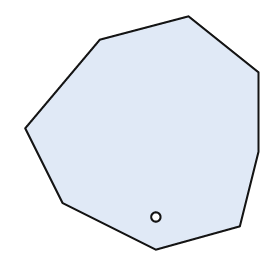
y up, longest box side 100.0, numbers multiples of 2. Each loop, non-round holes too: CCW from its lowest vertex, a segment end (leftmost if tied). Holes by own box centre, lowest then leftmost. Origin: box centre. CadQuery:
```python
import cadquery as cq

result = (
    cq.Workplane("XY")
    .moveTo(6.0, -50.0)
    .lineTo(42.0, -40.0)
    .lineTo(50.0, -8.0)
    .lineTo(50.0, 26.0)
    .lineTo(20.0, 50.0)
    .lineTo(-18.0, 40.0)
    .lineTo(-50.0, 2.0)
    .lineTo(-34.0, -30.0)
    .close()
    .moveTo(6.0, -36.0)
    .circle(2.0)
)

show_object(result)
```